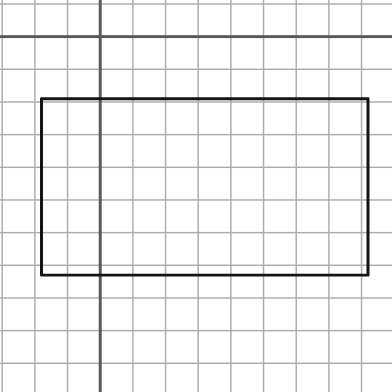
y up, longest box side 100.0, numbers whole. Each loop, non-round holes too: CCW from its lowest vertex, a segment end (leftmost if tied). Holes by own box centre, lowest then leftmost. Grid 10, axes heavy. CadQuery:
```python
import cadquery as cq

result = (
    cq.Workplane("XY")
    .moveTo(-18.0, -73.0)
    .lineTo(82.0, -73.0)
    .lineTo(82.0, -19.0)
    .lineTo(-18.0, -19.0)
    .close()
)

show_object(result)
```